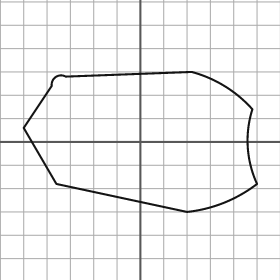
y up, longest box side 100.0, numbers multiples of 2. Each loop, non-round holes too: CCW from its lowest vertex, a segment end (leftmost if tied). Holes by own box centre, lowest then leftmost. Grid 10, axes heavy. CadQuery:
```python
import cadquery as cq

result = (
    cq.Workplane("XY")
    .moveTo(20.0, -30.0)
    .threePointArc((36.0, -26.0), (50.0, -18.0))
    .threePointArc((46.0, -2.0), (48.0, 14.0))
    .threePointArc((36.0, 24.0), (22.0, 30.0))
    .lineTo(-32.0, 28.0)
    .threePointArc((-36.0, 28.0), (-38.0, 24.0))
    .lineTo(-50.0, 6.0)
    .lineTo(-36.0, -18.0)
    .close()
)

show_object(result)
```